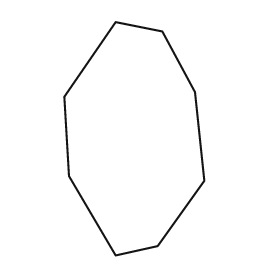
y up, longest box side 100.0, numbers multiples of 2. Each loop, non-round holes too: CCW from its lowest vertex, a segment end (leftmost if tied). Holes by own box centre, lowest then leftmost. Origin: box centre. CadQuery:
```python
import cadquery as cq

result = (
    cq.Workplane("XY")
    .moveTo(-8.0, -50.0)
    .lineTo(10.0, -46.0)
    .lineTo(30.0, -18.0)
    .lineTo(26.0, 20.0)
    .lineTo(12.0, 46.0)
    .lineTo(-8.0, 50.0)
    .lineTo(-30.0, 18.0)
    .lineTo(-28.0, -16.0)
    .close()
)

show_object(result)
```